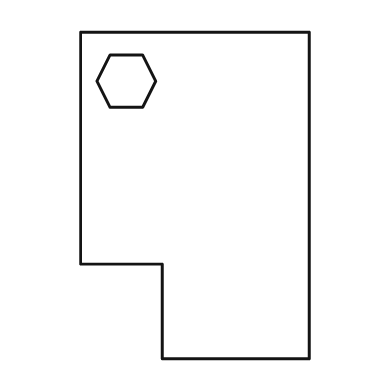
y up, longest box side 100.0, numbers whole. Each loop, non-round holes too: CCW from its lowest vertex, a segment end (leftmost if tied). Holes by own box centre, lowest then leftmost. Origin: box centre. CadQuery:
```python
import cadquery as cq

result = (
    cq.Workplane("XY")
    .moveTo(-10.0, -50.0)
    .lineTo(35.0, -50.0)
    .lineTo(35.0, 50.0)
    .lineTo(-35.0, 50.0)
    .lineTo(-35.0, -21.0)
    .lineTo(-10.0, -21.0)
    .close()
    .moveTo(-26.0, 27.0)
    .lineTo(-16.0, 27.0)
    .lineTo(-12.0, 35.0)
    .lineTo(-16.0, 43.0)
    .lineTo(-26.0, 43.0)
    .lineTo(-30.0, 35.0)
    .close()
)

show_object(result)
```